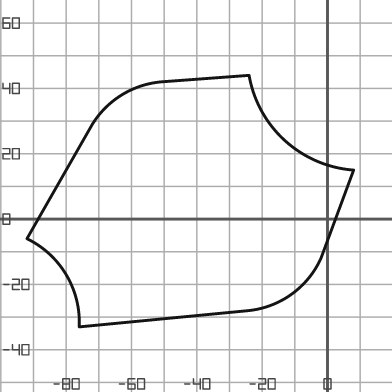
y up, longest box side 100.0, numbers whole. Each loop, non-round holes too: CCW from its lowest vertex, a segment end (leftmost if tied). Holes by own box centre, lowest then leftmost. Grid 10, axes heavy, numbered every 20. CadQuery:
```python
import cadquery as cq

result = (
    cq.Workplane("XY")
    .moveTo(-76.0, -33.0)
    .lineTo(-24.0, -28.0)
    .threePointArc((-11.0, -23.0), (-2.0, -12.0))
    .lineTo(8.0, 15.0)
    .threePointArc((-13.0, 24.0), (-24.0, 44.0))
    .lineTo(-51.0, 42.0)
    .threePointArc((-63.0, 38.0), (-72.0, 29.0))
    .lineTo(-92.0, -6.0)
    .threePointArc((-80.0, -17.0), (-76.0, -33.0))
    .close()
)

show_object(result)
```